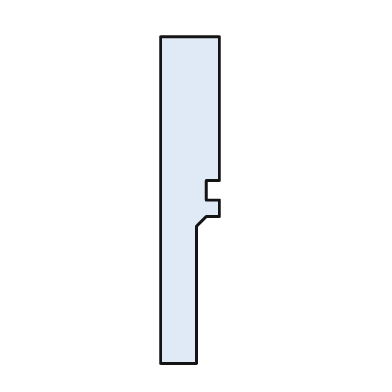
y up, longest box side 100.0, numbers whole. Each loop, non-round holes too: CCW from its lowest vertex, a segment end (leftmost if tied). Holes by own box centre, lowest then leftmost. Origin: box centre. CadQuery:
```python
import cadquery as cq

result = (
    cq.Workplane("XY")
    .moveTo(-9.0, -50.0)
    .lineTo(2.0, -50.0)
    .lineTo(2.0, -8.0)
    .lineTo(5.0, -5.0)
    .lineTo(9.0, -5.0)
    .lineTo(9.0, 0.0)
    .lineTo(5.0, 0.0)
    .lineTo(5.0, 6.0)
    .lineTo(9.0, 6.0)
    .lineTo(9.0, 50.0)
    .lineTo(-9.0, 50.0)
    .close()
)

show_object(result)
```